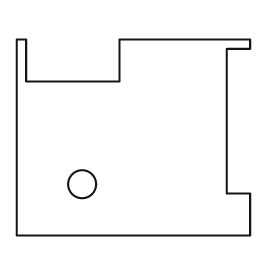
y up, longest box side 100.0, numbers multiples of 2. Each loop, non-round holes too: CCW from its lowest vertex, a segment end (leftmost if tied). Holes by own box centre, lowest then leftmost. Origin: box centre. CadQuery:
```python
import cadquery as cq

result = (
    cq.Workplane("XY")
    .moveTo(-50.0, -42.0)
    .lineTo(50.0, -42.0)
    .lineTo(50.0, -24.0)
    .lineTo(40.0, -24.0)
    .lineTo(40.0, 38.0)
    .lineTo(50.0, 38.0)
    .lineTo(50.0, 42.0)
    .lineTo(-6.0, 42.0)
    .lineTo(-6.0, 24.0)
    .lineTo(-46.0, 24.0)
    .lineTo(-46.0, 42.0)
    .lineTo(-50.0, 42.0)
    .close()
    .moveTo(-22.0, -20.0)
    .circle(6.0)
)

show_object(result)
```